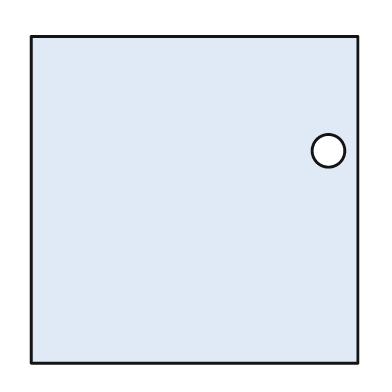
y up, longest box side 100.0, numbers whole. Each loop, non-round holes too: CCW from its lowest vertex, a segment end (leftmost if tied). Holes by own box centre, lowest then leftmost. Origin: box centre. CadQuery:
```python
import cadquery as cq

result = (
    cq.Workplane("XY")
    .moveTo(-50.0, -50.0)
    .lineTo(50.0, -50.0)
    .lineTo(50.0, 50.0)
    .lineTo(-50.0, 50.0)
    .close()
    .moveTo(41.0, 15.0)
    .circle(5.0)
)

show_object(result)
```